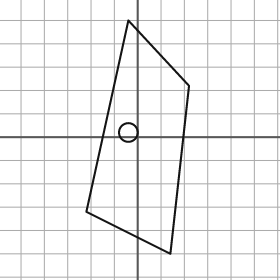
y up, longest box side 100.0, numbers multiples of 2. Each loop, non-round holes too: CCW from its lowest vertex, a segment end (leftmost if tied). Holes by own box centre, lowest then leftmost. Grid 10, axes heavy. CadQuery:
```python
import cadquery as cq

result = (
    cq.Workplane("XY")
    .moveTo(14.0, -50.0)
    .lineTo(22.0, 22.0)
    .lineTo(-4.0, 50.0)
    .lineTo(-22.0, -32.0)
    .close()
    .moveTo(-4.0, 2.0)
    .circle(4.0)
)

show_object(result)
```